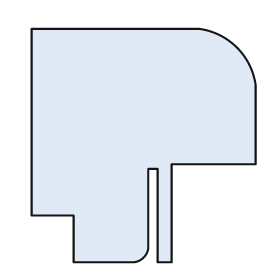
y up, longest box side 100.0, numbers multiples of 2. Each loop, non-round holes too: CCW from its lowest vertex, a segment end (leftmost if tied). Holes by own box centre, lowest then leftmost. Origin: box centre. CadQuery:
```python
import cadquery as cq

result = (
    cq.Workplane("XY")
    .moveTo(-30.0, -50.0)
    .lineTo(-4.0, -50.0)
    .threePointArc((0.0, -48.0), (2.0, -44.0))
    .lineTo(2.0, -10.0)
    .lineTo(6.0, -10.0)
    .lineTo(6.0, -50.0)
    .lineTo(12.0, -50.0)
    .lineTo(12.0, -8.0)
    .lineTo(48.0, -8.0)
    .lineTo(48.0, 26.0)
    .threePointArc((40.0, 42.0), (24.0, 50.0))
    .lineTo(-48.0, 50.0)
    .lineTo(-48.0, -30.0)
    .lineTo(-30.0, -30.0)
    .close()
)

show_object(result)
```